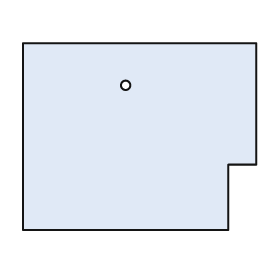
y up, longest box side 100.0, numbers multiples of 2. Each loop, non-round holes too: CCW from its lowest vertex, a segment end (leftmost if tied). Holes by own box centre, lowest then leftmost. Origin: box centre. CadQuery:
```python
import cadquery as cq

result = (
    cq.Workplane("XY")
    .moveTo(-50.0, -40.0)
    .lineTo(38.0, -40.0)
    .lineTo(38.0, -12.0)
    .lineTo(50.0, -12.0)
    .lineTo(50.0, 40.0)
    .lineTo(-50.0, 40.0)
    .close()
    .moveTo(-6.0, 22.0)
    .circle(2.0)
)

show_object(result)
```